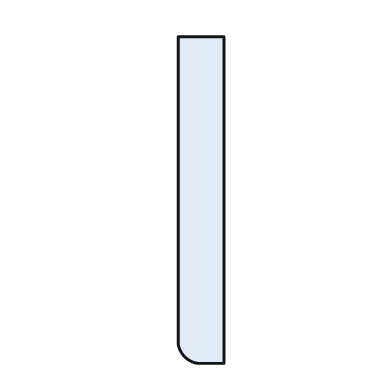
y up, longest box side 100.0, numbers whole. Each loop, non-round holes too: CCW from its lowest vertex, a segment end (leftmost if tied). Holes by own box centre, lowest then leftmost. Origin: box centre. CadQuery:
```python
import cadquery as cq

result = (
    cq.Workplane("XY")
    .moveTo(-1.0, -50.0)
    .lineTo(7.0, -50.0)
    .lineTo(7.0, 50.0)
    .lineTo(-7.0, 50.0)
    .lineTo(-7.0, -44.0)
    .threePointArc((-5.0, -48.0), (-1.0, -50.0))
    .close()
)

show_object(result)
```